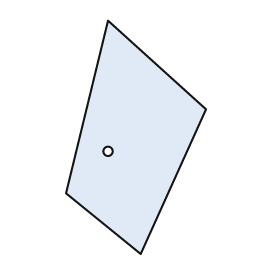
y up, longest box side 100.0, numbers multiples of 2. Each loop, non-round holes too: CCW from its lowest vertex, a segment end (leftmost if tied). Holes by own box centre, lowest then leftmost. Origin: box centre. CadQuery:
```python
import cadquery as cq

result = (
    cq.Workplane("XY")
    .moveTo(2.0, -50.0)
    .lineTo(30.0, 12.0)
    .lineTo(-12.0, 50.0)
    .lineTo(-30.0, -24.0)
    .close()
    .moveTo(-12.0, -6.0)
    .circle(2.0)
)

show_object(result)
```